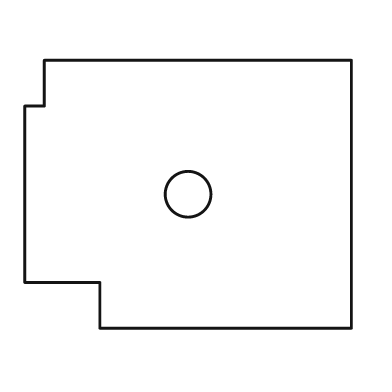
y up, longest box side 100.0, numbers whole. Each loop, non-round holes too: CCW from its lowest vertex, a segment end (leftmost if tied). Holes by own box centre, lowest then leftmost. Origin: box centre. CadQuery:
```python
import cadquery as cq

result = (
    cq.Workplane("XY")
    .moveTo(-27.0, -41.0)
    .lineTo(50.0, -41.0)
    .lineTo(50.0, 41.0)
    .lineTo(-44.0, 41.0)
    .lineTo(-44.0, 27.0)
    .lineTo(-50.0, 27.0)
    .lineTo(-50.0, -27.0)
    .lineTo(-27.0, -27.0)
    .close()
    .moveTo(0.0, 0.0)
    .circle(7.0)
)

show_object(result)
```